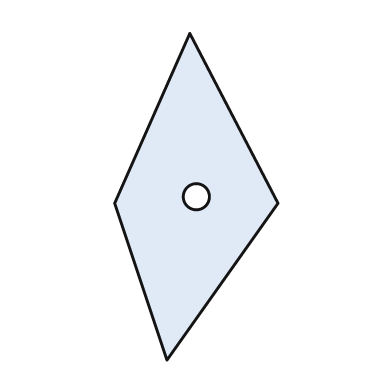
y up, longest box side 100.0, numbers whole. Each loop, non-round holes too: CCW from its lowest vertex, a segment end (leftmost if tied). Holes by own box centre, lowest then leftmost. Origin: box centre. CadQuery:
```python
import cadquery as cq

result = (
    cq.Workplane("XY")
    .moveTo(-9.0, -50.0)
    .lineTo(25.0, -2.0)
    .lineTo(-2.0, 50.0)
    .lineTo(-25.0, -2.0)
    .close()
    .moveTo(0.0, 0.0)
    .circle(4.0)
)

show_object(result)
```